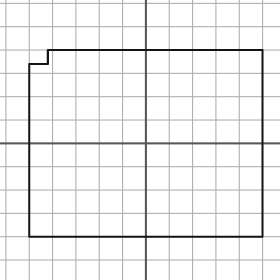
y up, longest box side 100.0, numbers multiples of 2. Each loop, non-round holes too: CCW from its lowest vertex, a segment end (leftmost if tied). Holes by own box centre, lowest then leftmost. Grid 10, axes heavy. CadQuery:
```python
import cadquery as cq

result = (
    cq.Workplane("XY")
    .moveTo(-50.0, -40.0)
    .lineTo(50.0, -40.0)
    .lineTo(50.0, 40.0)
    .lineTo(-42.0, 40.0)
    .lineTo(-42.0, 34.0)
    .lineTo(-50.0, 34.0)
    .close()
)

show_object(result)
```